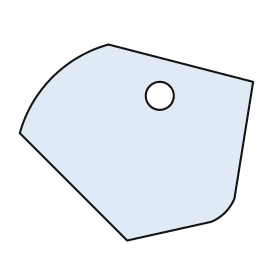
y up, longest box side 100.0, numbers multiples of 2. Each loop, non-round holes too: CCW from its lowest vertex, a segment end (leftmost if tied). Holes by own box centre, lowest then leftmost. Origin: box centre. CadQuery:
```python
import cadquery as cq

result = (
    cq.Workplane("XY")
    .moveTo(-4.0, -42.0)
    .lineTo(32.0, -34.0)
    .threePointArc((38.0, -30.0), (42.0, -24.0))
    .lineTo(50.0, 26.0)
    .lineTo(-12.0, 42.0)
    .threePointArc((-36.0, 28.0), (-50.0, 4.0))
    .close()
    .moveTo(10.0, 20.0)
    .circle(6.0)
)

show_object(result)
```